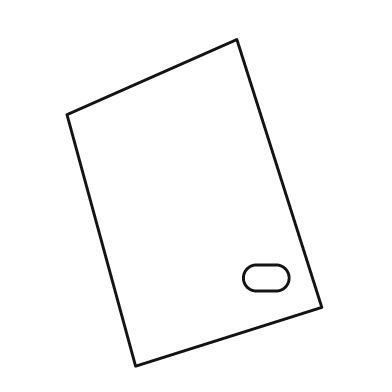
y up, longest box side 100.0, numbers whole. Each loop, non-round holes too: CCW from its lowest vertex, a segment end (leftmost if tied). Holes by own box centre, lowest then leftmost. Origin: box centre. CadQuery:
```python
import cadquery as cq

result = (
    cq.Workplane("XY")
    .moveTo(-18.0, -50.0)
    .lineTo(39.0, -32.0)
    .lineTo(13.0, 50.0)
    .lineTo(-39.0, 27.0)
    .close()
    .moveTo(19.0, -27.0)
    .lineTo(25.0, -27.0)
    .threePointArc((29.0, -23.0), (25.0, -19.0))
    .lineTo(19.0, -19.0)
    .threePointArc((15.0, -23.0), (19.0, -27.0))
    .close()
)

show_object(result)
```